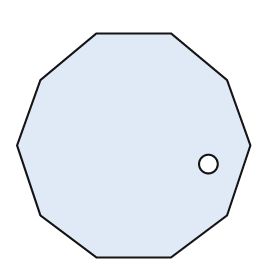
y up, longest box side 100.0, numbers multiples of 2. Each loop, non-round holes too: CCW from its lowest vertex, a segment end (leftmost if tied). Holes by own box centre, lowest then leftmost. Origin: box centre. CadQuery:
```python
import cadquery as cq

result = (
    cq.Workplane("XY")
    .moveTo(-16.0, -48.0)
    .lineTo(16.0, -48.0)
    .lineTo(40.0, -30.0)
    .lineTo(50.0, 0.0)
    .lineTo(40.0, 28.0)
    .lineTo(16.0, 48.0)
    .lineTo(-16.0, 48.0)
    .lineTo(-40.0, 28.0)
    .lineTo(-50.0, 0.0)
    .lineTo(-40.0, -30.0)
    .close()
    .moveTo(32.0, -8.0)
    .circle(4.0)
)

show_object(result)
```